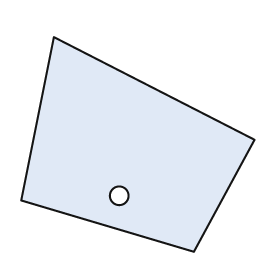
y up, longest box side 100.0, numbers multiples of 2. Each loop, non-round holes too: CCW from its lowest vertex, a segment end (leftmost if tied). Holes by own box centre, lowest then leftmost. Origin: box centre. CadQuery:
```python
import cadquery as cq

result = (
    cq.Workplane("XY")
    .moveTo(24.0, -46.0)
    .lineTo(50.0, 2.0)
    .lineTo(-36.0, 46.0)
    .lineTo(-50.0, -24.0)
    .close()
    .moveTo(-8.0, -22.0)
    .circle(4.0)
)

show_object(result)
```